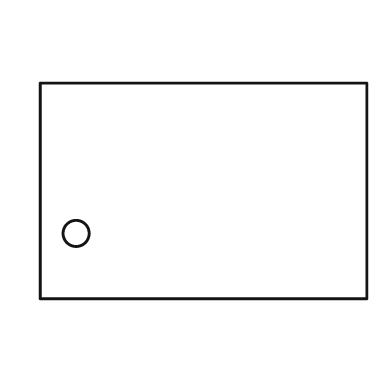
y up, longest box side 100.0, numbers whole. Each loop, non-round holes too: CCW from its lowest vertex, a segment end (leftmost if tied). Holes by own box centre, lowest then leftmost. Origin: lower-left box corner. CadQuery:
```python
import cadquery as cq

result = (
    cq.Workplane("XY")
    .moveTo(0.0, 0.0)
    .lineTo(100.0, 0.0)
    .lineTo(100.0, 66.0)
    .lineTo(0.0, 66.0)
    .close()
    .moveTo(11.0, 20.0)
    .circle(4.0)
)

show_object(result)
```